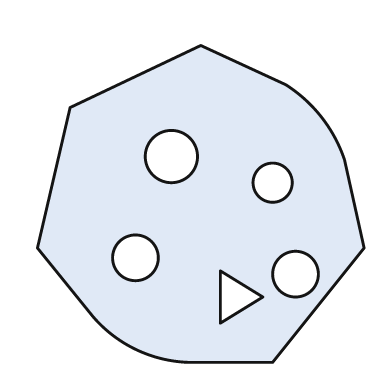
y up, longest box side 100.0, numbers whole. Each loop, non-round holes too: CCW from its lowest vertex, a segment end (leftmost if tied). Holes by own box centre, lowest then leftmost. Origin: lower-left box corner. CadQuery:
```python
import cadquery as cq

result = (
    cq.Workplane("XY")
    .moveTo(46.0, 0.0)
    .lineTo(72.0, 0.0)
    .lineTo(100.0, 35.0)
    .lineTo(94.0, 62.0)
    .threePointArc((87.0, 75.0), (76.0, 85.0))
    .lineTo(50.0, 97.0)
    .lineTo(10.0, 78.0)
    .lineTo(0.0, 35.0)
    .lineTo(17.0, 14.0)
    .threePointArc((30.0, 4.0), (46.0, 0.0))
    .close()
    .moveTo(56.0, 12.0)
    .lineTo(69.0, 20.0)
    .lineTo(56.0, 28.0)
    .close()
    .moveTo(79.0, 27.0)
    .circle(7.0)
    .moveTo(30.0, 32.0)
    .circle(7.0)
    .moveTo(72.0, 55.0)
    .circle(6.0)
    .moveTo(41.0, 63.0)
    .circle(8.0)
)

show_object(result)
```